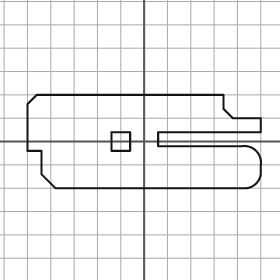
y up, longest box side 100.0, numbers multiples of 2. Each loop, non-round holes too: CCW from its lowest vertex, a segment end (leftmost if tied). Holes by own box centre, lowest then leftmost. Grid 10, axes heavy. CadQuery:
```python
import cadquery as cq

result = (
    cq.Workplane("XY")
    .moveTo(-38.0, -20.0)
    .lineTo(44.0, -20.0)
    .threePointArc((48.0, -18.0), (50.0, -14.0))
    .lineTo(50.0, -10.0)
    .threePointArc((48.0, -4.0), (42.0, -2.0))
    .lineTo(6.0, -2.0)
    .lineTo(6.0, 4.0)
    .lineTo(50.0, 4.0)
    .lineTo(50.0, 10.0)
    .lineTo(38.0, 10.0)
    .lineTo(34.0, 14.0)
    .lineTo(34.0, 20.0)
    .lineTo(-46.0, 20.0)
    .lineTo(-50.0, 16.0)
    .lineTo(-50.0, -4.0)
    .lineTo(-44.0, -4.0)
    .lineTo(-44.0, -14.0)
    .close()
    .moveTo(-14.0, -4.0)
    .lineTo(-6.0, -4.0)
    .lineTo(-6.0, 4.0)
    .lineTo(-14.0, 4.0)
    .close()
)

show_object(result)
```